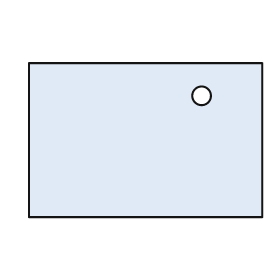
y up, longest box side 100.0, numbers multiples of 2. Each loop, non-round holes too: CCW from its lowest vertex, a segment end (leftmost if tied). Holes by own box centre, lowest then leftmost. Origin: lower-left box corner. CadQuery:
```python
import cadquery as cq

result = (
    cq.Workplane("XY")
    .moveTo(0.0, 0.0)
    .lineTo(100.0, 0.0)
    .lineTo(100.0, 66.0)
    .lineTo(0.0, 66.0)
    .close()
    .moveTo(74.0, 52.0)
    .circle(4.0)
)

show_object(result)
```